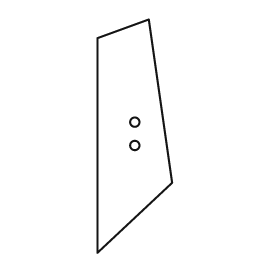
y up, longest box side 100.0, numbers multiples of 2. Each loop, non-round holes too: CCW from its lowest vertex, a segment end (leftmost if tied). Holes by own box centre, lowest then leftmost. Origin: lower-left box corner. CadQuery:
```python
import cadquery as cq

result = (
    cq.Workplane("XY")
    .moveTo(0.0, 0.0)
    .lineTo(32.0, 30.0)
    .lineTo(22.0, 100.0)
    .lineTo(0.0, 92.0)
    .close()
    .moveTo(16.0, 46.0)
    .circle(2.0)
    .moveTo(16.0, 56.0)
    .circle(2.0)
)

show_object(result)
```